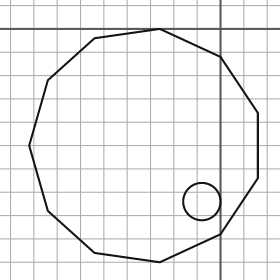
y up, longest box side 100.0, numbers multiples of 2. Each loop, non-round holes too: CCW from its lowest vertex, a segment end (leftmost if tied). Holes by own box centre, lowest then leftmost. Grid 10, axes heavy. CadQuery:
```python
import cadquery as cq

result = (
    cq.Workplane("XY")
    .moveTo(-26.0, -100.0)
    .lineTo(0.0, -88.0)
    .lineTo(16.0, -64.0)
    .lineTo(16.0, -36.0)
    .lineTo(0.0, -12.0)
    .lineTo(-26.0, 0.0)
    .lineTo(-54.0, -4.0)
    .lineTo(-74.0, -22.0)
    .lineTo(-82.0, -50.0)
    .lineTo(-74.0, -78.0)
    .lineTo(-54.0, -96.0)
    .close()
    .moveTo(-8.0, -74.0)
    .circle(8.0)
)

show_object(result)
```